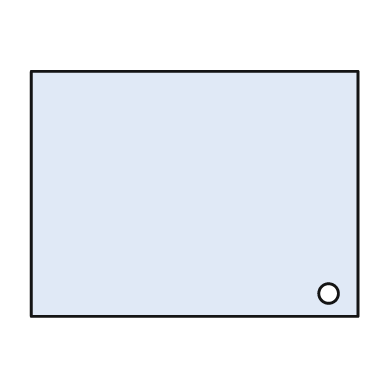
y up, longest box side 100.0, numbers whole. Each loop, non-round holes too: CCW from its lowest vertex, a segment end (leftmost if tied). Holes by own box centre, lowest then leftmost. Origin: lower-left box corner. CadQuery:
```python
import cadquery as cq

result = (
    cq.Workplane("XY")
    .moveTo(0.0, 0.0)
    .lineTo(100.0, 0.0)
    .lineTo(100.0, 75.0)
    .lineTo(0.0, 75.0)
    .close()
    .moveTo(91.0, 7.0)
    .circle(3.0)
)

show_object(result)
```